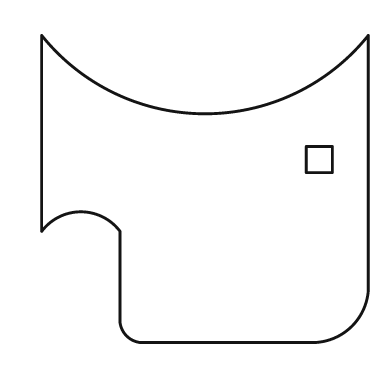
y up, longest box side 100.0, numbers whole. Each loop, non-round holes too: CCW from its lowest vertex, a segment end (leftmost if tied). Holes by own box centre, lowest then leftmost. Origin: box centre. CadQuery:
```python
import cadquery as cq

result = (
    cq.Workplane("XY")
    .moveTo(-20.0, -47.0)
    .lineTo(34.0, -47.0)
    .threePointArc((45.0, -42.0), (50.0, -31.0))
    .lineTo(50.0, 47.0)
    .threePointArc((0.0, 23.0), (-50.0, 47.0))
    .lineTo(-50.0, -13.0)
    .threePointArc((-38.0, -7.0), (-26.0, -13.0))
    .lineTo(-26.0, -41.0)
    .threePointArc((-24.0, -45.0), (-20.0, -47.0))
    .close()
    .moveTo(31.0, 5.0)
    .lineTo(39.0, 5.0)
    .lineTo(39.0, 13.0)
    .lineTo(31.0, 13.0)
    .close()
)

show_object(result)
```